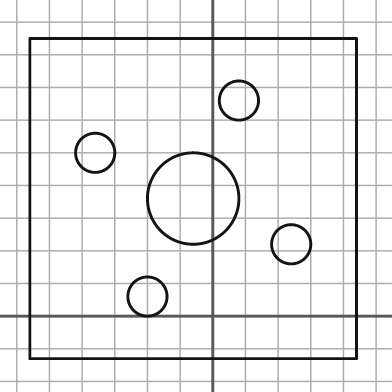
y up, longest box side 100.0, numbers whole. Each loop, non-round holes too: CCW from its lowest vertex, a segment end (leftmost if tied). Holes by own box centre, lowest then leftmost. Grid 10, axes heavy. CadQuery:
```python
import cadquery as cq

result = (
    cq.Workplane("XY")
    .moveTo(-56.0, -13.0)
    .lineTo(44.0, -13.0)
    .lineTo(44.0, 85.0)
    .lineTo(-56.0, 85.0)
    .close()
    .moveTo(-20.0, 6.0)
    .circle(6.0)
    .moveTo(24.0, 22.0)
    .circle(6.0)
    .moveTo(-6.0, 36.0)
    .circle(14.0)
    .moveTo(-36.0, 50.0)
    .circle(6.0)
    .moveTo(8.0, 66.0)
    .circle(6.0)
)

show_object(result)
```